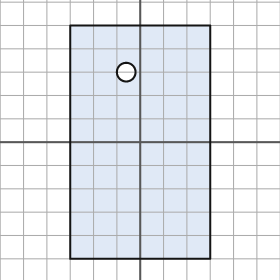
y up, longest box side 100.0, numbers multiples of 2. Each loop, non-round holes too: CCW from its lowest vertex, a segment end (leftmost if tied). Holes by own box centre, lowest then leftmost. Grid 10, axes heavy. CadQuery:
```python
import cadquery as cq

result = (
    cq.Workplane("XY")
    .moveTo(-30.0, -50.0)
    .lineTo(30.0, -50.0)
    .lineTo(30.0, 50.0)
    .lineTo(-30.0, 50.0)
    .close()
    .moveTo(-6.0, 30.0)
    .circle(4.0)
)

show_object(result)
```